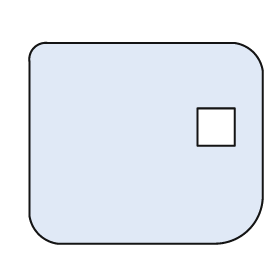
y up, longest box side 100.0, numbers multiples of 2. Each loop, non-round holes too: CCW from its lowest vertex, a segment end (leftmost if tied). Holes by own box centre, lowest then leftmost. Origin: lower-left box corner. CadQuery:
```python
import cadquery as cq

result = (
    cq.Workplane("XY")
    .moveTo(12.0, 0.0)
    .lineTo(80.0, 0.0)
    .threePointArc((94.0, 6.0), (100.0, 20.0))
    .lineTo(100.0, 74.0)
    .threePointArc((96.0, 82.0), (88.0, 86.0))
    .lineTo(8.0, 86.0)
    .threePointArc((2.0, 84.0), (0.0, 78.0))
    .lineTo(0.0, 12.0)
    .threePointArc((4.0, 4.0), (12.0, 0.0))
    .close()
    .moveTo(72.0, 42.0)
    .lineTo(88.0, 42.0)
    .lineTo(88.0, 58.0)
    .lineTo(72.0, 58.0)
    .close()
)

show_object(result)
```